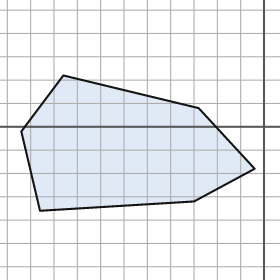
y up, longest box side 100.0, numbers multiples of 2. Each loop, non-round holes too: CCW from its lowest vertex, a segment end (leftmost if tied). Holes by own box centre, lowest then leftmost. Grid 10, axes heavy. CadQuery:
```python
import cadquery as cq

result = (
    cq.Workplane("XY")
    .moveTo(-96.0, -36.0)
    .lineTo(-30.0, -32.0)
    .lineTo(-4.0, -18.0)
    .lineTo(-28.0, 8.0)
    .lineTo(-86.0, 22.0)
    .lineTo(-104.0, -2.0)
    .close()
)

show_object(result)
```